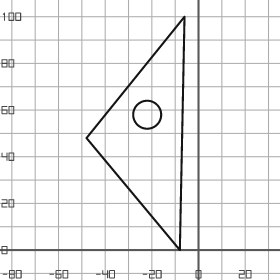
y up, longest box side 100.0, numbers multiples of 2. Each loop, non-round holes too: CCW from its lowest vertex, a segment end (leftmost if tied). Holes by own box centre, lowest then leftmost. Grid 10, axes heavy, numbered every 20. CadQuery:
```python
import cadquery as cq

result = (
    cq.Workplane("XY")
    .moveTo(-8.0, 0.0)
    .lineTo(-6.0, 100.0)
    .lineTo(-48.0, 48.0)
    .close()
    .moveTo(-22.0, 58.0)
    .circle(6.0)
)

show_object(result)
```